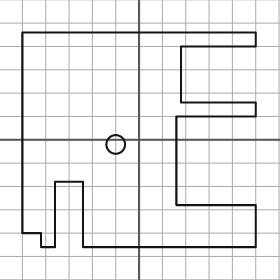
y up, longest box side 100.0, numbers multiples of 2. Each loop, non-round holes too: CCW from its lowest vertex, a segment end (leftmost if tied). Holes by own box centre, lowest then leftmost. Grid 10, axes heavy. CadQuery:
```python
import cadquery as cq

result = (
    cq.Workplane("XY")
    .moveTo(-42.0, -46.0)
    .lineTo(-36.0, -46.0)
    .lineTo(-36.0, -18.0)
    .lineTo(-24.0, -18.0)
    .lineTo(-24.0, -46.0)
    .lineTo(50.0, -46.0)
    .lineTo(50.0, -28.0)
    .lineTo(16.0, -28.0)
    .lineTo(16.0, 10.0)
    .lineTo(50.0, 10.0)
    .lineTo(50.0, 16.0)
    .lineTo(18.0, 16.0)
    .lineTo(18.0, 40.0)
    .lineTo(50.0, 40.0)
    .lineTo(50.0, 46.0)
    .lineTo(-50.0, 46.0)
    .lineTo(-50.0, -40.0)
    .lineTo(-42.0, -40.0)
    .close()
    .moveTo(-10.0, -2.0)
    .circle(4.0)
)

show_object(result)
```